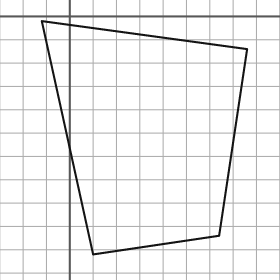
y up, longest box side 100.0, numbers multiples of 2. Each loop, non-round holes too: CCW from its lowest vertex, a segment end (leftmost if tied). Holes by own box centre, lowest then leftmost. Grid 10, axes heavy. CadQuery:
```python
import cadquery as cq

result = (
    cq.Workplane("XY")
    .moveTo(10.0, -102.0)
    .lineTo(64.0, -94.0)
    .lineTo(76.0, -14.0)
    .lineTo(-12.0, -2.0)
    .close()
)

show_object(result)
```